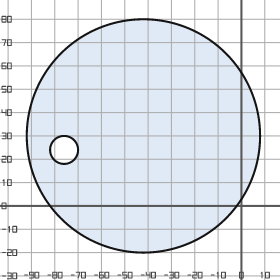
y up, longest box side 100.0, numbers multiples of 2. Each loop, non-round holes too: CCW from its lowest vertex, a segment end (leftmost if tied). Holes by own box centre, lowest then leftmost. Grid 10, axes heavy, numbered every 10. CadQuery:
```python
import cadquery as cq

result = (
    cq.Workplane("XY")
    .moveTo(-42.0, 30.0)
    .circle(50.0)
    .moveTo(-76.0, 24.0)
    .circle(6.0)
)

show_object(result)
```